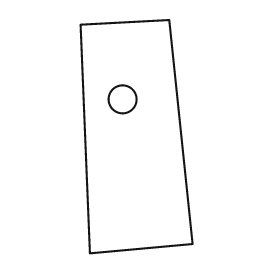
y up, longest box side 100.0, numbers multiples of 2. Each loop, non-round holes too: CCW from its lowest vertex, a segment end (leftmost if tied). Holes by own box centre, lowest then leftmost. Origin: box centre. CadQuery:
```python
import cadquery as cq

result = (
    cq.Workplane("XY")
    .moveTo(-20.0, -50.0)
    .lineTo(24.0, -46.0)
    .lineTo(14.0, 50.0)
    .lineTo(-24.0, 48.0)
    .close()
    .moveTo(-6.0, 16.0)
    .circle(6.0)
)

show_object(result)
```